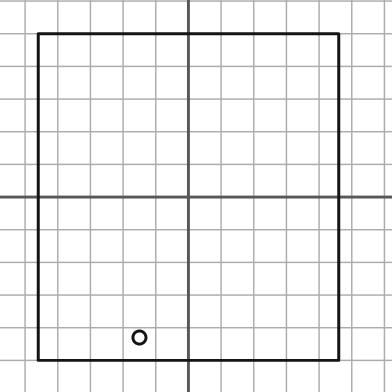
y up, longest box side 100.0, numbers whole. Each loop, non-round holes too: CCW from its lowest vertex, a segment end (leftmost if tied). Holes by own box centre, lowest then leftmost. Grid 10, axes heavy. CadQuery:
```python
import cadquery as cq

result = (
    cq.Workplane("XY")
    .moveTo(-46.0, -50.0)
    .lineTo(46.0, -50.0)
    .lineTo(46.0, 50.0)
    .lineTo(-46.0, 50.0)
    .close()
    .moveTo(-15.0, -43.0)
    .circle(2.0)
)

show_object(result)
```